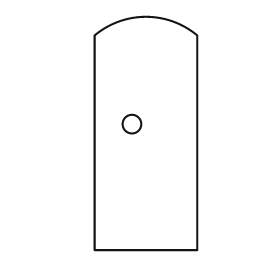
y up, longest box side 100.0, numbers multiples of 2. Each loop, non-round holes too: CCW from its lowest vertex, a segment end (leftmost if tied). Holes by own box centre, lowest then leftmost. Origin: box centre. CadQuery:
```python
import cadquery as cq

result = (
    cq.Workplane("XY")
    .moveTo(-22.0, -50.0)
    .lineTo(22.0, -50.0)
    .lineTo(22.0, 42.0)
    .threePointArc((0.0, 50.0), (-22.0, 42.0))
    .close()
    .moveTo(-6.0, 4.0)
    .circle(4.0)
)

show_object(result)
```